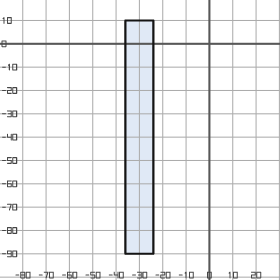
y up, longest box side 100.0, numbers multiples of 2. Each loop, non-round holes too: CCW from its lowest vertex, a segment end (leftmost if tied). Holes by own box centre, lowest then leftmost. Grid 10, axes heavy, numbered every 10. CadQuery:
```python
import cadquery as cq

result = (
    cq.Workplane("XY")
    .moveTo(-36.0, -90.0)
    .lineTo(-24.0, -90.0)
    .lineTo(-24.0, 10.0)
    .lineTo(-36.0, 10.0)
    .close()
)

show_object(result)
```